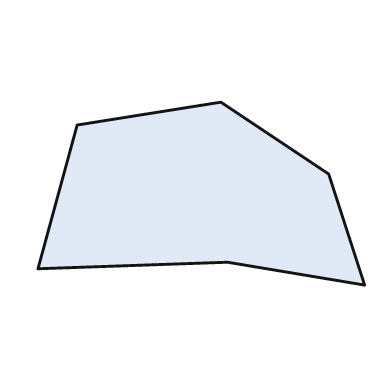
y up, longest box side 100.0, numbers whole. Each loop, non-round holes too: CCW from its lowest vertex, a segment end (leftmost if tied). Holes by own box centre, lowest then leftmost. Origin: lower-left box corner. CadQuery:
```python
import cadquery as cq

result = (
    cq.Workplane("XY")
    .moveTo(100.0, 0.0)
    .lineTo(89.0, 34.0)
    .lineTo(56.0, 56.0)
    .lineTo(12.0, 49.0)
    .lineTo(0.0, 5.0)
    .lineTo(58.0, 7.0)
    .close()
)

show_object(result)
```